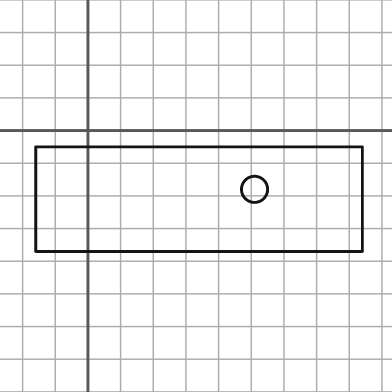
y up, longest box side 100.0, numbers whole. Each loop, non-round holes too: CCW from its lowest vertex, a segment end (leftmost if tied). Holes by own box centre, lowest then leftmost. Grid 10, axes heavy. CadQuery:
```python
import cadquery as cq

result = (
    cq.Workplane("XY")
    .moveTo(-16.0, -37.0)
    .lineTo(84.0, -37.0)
    .lineTo(84.0, -5.0)
    .lineTo(-16.0, -5.0)
    .close()
    .moveTo(51.0, -18.0)
    .circle(4.0)
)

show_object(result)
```